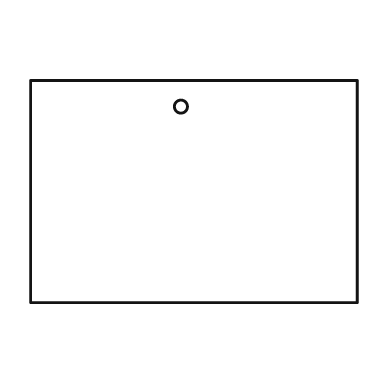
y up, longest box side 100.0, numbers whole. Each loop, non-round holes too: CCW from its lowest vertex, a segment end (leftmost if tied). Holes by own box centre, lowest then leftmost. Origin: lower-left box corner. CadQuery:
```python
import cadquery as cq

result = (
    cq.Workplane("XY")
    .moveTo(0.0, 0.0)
    .lineTo(100.0, 0.0)
    .lineTo(100.0, 68.0)
    .lineTo(0.0, 68.0)
    .close()
    .moveTo(46.0, 60.0)
    .circle(2.0)
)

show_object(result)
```